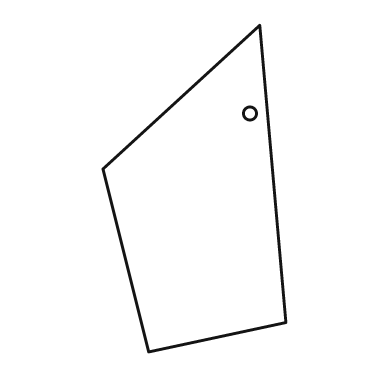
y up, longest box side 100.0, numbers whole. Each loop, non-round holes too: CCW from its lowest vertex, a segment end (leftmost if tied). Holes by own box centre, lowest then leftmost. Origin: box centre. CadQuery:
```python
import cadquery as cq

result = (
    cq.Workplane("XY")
    .moveTo(-14.0, -50.0)
    .lineTo(28.0, -41.0)
    .lineTo(20.0, 50.0)
    .lineTo(-28.0, 6.0)
    .close()
    .moveTo(17.0, 23.0)
    .circle(2.0)
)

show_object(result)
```